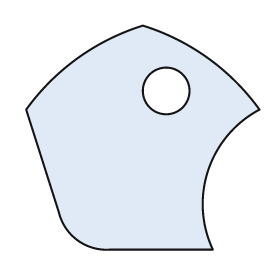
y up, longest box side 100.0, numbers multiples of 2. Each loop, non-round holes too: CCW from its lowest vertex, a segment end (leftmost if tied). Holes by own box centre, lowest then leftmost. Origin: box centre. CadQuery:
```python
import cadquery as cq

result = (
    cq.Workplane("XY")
    .moveTo(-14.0, -48.0)
    .lineTo(30.0, -48.0)
    .threePointArc((28.0, -14.0), (50.0, 12.0))
    .threePointArc((28.0, 34.0), (0.0, 48.0))
    .threePointArc((-28.0, 34.0), (-50.0, 12.0))
    .lineTo(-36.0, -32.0)
    .threePointArc((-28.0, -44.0), (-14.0, -48.0))
    .close()
    .moveTo(10.0, 20.0)
    .circle(10.0)
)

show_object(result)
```